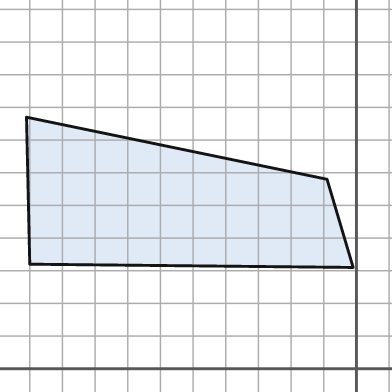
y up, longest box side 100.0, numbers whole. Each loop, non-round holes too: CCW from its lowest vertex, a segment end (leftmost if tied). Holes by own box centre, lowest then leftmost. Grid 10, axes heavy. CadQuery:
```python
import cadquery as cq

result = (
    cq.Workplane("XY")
    .moveTo(-1.0, 31.0)
    .lineTo(-9.0, 58.0)
    .lineTo(-101.0, 77.0)
    .lineTo(-100.0, 32.0)
    .close()
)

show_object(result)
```